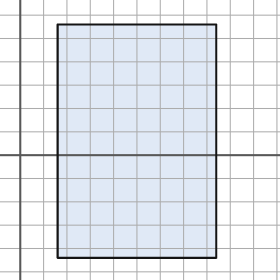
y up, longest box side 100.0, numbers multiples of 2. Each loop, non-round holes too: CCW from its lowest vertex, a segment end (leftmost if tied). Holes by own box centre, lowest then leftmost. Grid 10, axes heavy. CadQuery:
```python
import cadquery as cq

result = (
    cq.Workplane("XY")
    .moveTo(16.0, -44.0)
    .lineTo(84.0, -44.0)
    .lineTo(84.0, 56.0)
    .lineTo(16.0, 56.0)
    .close()
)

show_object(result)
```